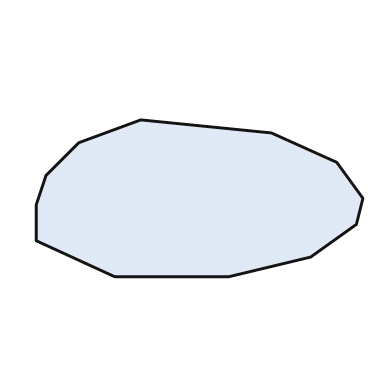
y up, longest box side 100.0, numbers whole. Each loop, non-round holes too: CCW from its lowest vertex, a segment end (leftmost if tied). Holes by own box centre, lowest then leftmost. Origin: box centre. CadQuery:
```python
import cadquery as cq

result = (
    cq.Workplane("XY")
    .moveTo(-26.0, -24.0)
    .lineTo(9.0, -24.0)
    .lineTo(34.0, -18.0)
    .lineTo(48.0, -8.0)
    .lineTo(50.0, 0.0)
    .lineTo(42.0, 11.0)
    .lineTo(22.0, 20.0)
    .lineTo(-18.0, 24.0)
    .lineTo(-37.0, 17.0)
    .lineTo(-47.0, 7.0)
    .lineTo(-50.0, -2.0)
    .lineTo(-50.0, -13.0)
    .close()
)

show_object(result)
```